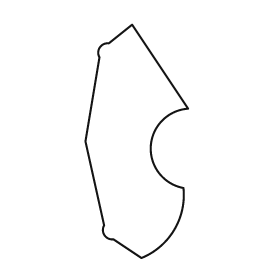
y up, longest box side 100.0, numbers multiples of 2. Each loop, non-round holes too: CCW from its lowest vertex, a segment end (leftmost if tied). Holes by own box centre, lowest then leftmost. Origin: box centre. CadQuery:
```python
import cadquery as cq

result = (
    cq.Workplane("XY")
    .moveTo(2.0, -50.0)
    .threePointArc((16.0, -38.0), (20.0, -20.0))
    .threePointArc((6.0, -2.0), (22.0, 14.0))
    .lineTo(-2.0, 50.0)
    .lineTo(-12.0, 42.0)
    .threePointArc((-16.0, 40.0), (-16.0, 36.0))
    .lineTo(-22.0, 0.0)
    .lineTo(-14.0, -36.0)
    .threePointArc((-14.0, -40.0), (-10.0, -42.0))
    .close()
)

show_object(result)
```